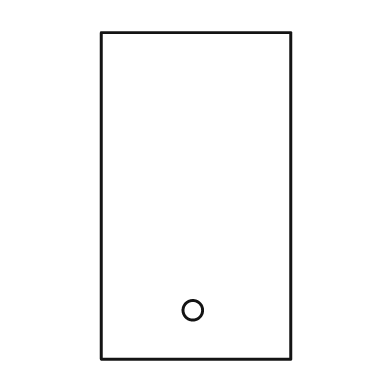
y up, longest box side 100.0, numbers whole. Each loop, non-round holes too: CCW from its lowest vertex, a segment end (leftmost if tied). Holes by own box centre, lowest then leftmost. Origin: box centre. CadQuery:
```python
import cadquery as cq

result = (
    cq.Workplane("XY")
    .moveTo(-29.0, -50.0)
    .lineTo(29.0, -50.0)
    .lineTo(29.0, 50.0)
    .lineTo(-29.0, 50.0)
    .close()
    .moveTo(-1.0, -35.0)
    .circle(3.0)
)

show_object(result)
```